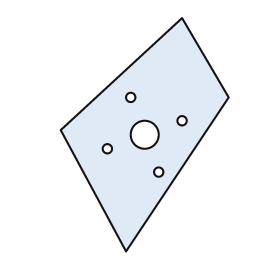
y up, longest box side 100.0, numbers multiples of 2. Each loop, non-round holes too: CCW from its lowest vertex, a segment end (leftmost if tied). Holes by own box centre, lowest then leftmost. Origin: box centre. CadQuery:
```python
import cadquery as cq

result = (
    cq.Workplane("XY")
    .moveTo(-8.0, -50.0)
    .lineTo(36.0, 16.0)
    .lineTo(16.0, 50.0)
    .lineTo(-36.0, 2.0)
    .close()
    .moveTo(6.0, -16.0)
    .circle(2.0)
    .moveTo(-16.0, -6.0)
    .circle(2.0)
    .moveTo(0.0, 0.0)
    .circle(6.0)
    .moveTo(16.0, 6.0)
    .circle(2.0)
    .moveTo(-6.0, 16.0)
    .circle(2.0)
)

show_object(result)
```